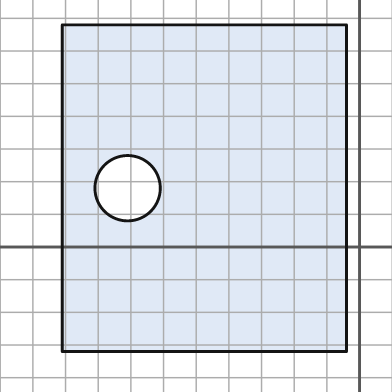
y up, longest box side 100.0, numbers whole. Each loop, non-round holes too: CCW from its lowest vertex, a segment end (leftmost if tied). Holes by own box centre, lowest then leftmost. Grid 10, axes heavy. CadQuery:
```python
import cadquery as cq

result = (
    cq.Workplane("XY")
    .moveTo(-91.0, -32.0)
    .lineTo(-4.0, -32.0)
    .lineTo(-4.0, 68.0)
    .lineTo(-91.0, 68.0)
    .close()
    .moveTo(-71.0, 18.0)
    .circle(10.0)
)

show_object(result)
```